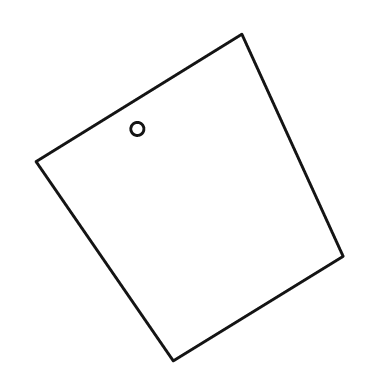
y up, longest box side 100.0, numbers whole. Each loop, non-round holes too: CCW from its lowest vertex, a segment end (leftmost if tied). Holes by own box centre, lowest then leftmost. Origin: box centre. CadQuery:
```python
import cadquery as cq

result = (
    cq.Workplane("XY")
    .moveTo(-5.0, -50.0)
    .lineTo(47.0, -18.0)
    .lineTo(16.0, 50.0)
    .lineTo(-47.0, 11.0)
    .close()
    .moveTo(-16.0, 21.0)
    .circle(2.0)
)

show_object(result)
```